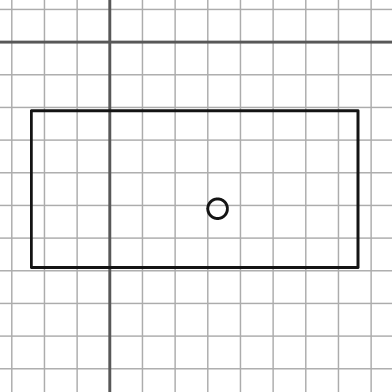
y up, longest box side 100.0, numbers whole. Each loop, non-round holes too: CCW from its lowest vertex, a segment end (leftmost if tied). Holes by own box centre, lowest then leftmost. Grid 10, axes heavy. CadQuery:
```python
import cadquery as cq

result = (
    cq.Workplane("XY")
    .moveTo(-24.0, -69.0)
    .lineTo(76.0, -69.0)
    .lineTo(76.0, -21.0)
    .lineTo(-24.0, -21.0)
    .close()
    .moveTo(33.0, -51.0)
    .circle(3.0)
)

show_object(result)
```